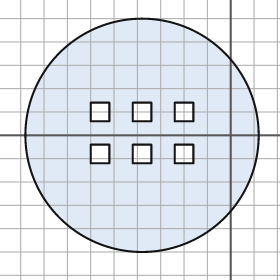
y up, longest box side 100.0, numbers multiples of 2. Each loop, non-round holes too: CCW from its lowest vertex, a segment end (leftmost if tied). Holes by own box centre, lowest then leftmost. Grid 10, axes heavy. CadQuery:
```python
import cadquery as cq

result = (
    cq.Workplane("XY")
    .moveTo(-38.0, 0.0)
    .circle(50.0)
    .moveTo(-60.0, -12.0)
    .lineTo(-52.0, -12.0)
    .lineTo(-52.0, -4.0)
    .lineTo(-60.0, -4.0)
    .close()
    .moveTo(-42.0, -12.0)
    .lineTo(-34.0, -12.0)
    .lineTo(-34.0, -4.0)
    .lineTo(-42.0, -4.0)
    .close()
    .moveTo(-24.0, -12.0)
    .lineTo(-16.0, -12.0)
    .lineTo(-16.0, -4.0)
    .lineTo(-24.0, -4.0)
    .close()
    .moveTo(-60.0, 6.0)
    .lineTo(-52.0, 6.0)
    .lineTo(-52.0, 14.0)
    .lineTo(-60.0, 14.0)
    .close()
    .moveTo(-42.0, 6.0)
    .lineTo(-34.0, 6.0)
    .lineTo(-34.0, 14.0)
    .lineTo(-42.0, 14.0)
    .close()
    .moveTo(-24.0, 6.0)
    .lineTo(-16.0, 6.0)
    .lineTo(-16.0, 14.0)
    .lineTo(-24.0, 14.0)
    .close()
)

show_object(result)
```